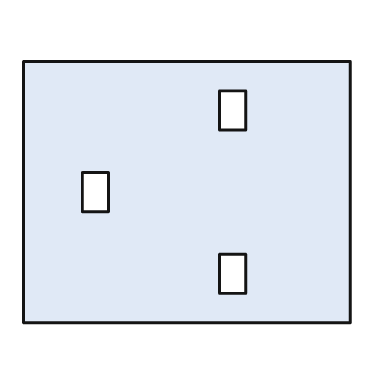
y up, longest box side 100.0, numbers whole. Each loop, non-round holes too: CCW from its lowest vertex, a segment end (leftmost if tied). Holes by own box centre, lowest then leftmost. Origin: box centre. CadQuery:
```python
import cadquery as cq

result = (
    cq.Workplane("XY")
    .moveTo(-50.0, -40.0)
    .lineTo(50.0, -40.0)
    .lineTo(50.0, 40.0)
    .lineTo(-50.0, 40.0)
    .close()
    .moveTo(10.0, -31.0)
    .lineTo(18.0, -31.0)
    .lineTo(18.0, -19.0)
    .lineTo(10.0, -19.0)
    .close()
    .moveTo(-32.0, -6.0)
    .lineTo(-24.0, -6.0)
    .lineTo(-24.0, 6.0)
    .lineTo(-32.0, 6.0)
    .close()
    .moveTo(10.0, 19.0)
    .lineTo(18.0, 19.0)
    .lineTo(18.0, 31.0)
    .lineTo(10.0, 31.0)
    .close()
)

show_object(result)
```